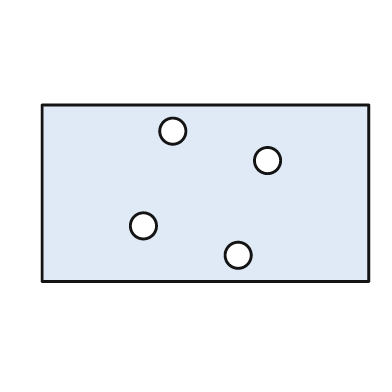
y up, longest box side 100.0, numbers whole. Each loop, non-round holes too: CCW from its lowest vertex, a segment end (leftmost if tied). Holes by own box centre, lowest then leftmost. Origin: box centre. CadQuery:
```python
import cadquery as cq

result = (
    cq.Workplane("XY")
    .moveTo(-50.0, -27.0)
    .lineTo(50.0, -27.0)
    .lineTo(50.0, 27.0)
    .lineTo(-50.0, 27.0)
    .close()
    .moveTo(10.0, -19.0)
    .circle(4.0)
    .moveTo(-19.0, -10.0)
    .circle(4.0)
    .moveTo(19.0, 10.0)
    .circle(4.0)
    .moveTo(-10.0, 19.0)
    .circle(4.0)
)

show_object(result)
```